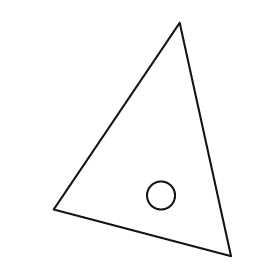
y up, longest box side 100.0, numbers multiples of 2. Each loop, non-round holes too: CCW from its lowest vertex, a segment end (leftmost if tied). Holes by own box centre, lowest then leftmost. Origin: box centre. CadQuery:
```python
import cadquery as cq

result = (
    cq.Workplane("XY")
    .moveTo(38.0, -50.0)
    .lineTo(16.0, 50.0)
    .lineTo(-38.0, -30.0)
    .close()
    .moveTo(8.0, -24.0)
    .circle(6.0)
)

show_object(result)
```